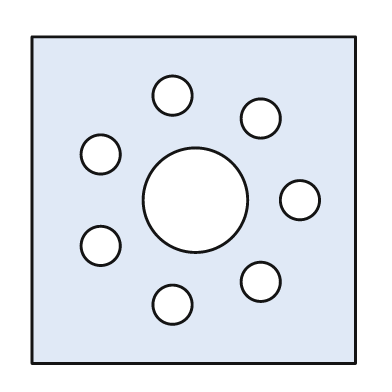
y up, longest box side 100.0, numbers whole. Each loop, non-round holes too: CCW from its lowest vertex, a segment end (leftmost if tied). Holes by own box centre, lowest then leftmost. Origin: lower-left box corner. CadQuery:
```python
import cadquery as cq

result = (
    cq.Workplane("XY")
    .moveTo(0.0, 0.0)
    .lineTo(99.0, 0.0)
    .lineTo(99.0, 100.0)
    .lineTo(0.0, 100.0)
    .close()
    .moveTo(43.0, 18.0)
    .circle(6.0)
    .moveTo(70.0, 25.0)
    .circle(6.0)
    .moveTo(21.0, 36.0)
    .circle(6.0)
    .moveTo(50.0, 50.0)
    .circle(16.0)
    .moveTo(82.0, 50.0)
    .circle(6.0)
    .moveTo(21.0, 64.0)
    .circle(6.0)
    .moveTo(70.0, 75.0)
    .circle(6.0)
    .moveTo(43.0, 82.0)
    .circle(6.0)
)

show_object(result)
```